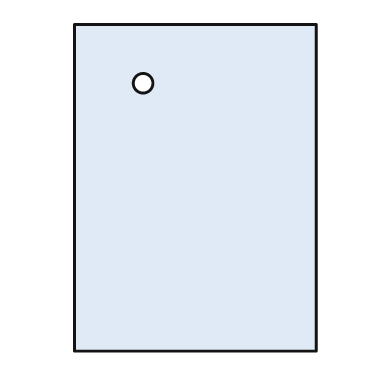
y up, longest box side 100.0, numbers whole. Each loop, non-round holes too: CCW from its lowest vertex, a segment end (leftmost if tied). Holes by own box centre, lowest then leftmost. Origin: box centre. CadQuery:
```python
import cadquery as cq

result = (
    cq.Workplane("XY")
    .moveTo(-37.0, -50.0)
    .lineTo(37.0, -50.0)
    .lineTo(37.0, 50.0)
    .lineTo(-37.0, 50.0)
    .close()
    .moveTo(-16.0, 32.0)
    .circle(3.0)
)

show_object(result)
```